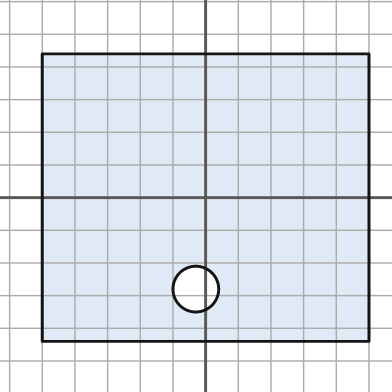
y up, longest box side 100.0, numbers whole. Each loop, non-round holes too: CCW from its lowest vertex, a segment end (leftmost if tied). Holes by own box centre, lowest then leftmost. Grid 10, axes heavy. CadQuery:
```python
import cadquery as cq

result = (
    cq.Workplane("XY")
    .moveTo(-50.0, -44.0)
    .lineTo(50.0, -44.0)
    .lineTo(50.0, 44.0)
    .lineTo(-50.0, 44.0)
    .close()
    .moveTo(-3.0, -28.0)
    .circle(7.0)
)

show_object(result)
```